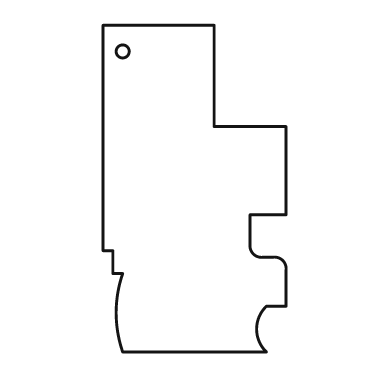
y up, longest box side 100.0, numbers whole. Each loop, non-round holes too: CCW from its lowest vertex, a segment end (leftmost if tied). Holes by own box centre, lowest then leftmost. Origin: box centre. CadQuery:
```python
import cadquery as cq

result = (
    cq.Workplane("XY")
    .moveTo(-22.0, -50.0)
    .lineTo(22.0, -50.0)
    .threePointArc((19.0, -43.0), (22.0, -36.0))
    .lineTo(28.0, -36.0)
    .lineTo(28.0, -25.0)
    .threePointArc((27.0, -22.0), (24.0, -21.0))
    .lineTo(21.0, -21.0)
    .threePointArc((18.0, -20.0), (17.0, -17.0))
    .lineTo(17.0, -8.0)
    .lineTo(28.0, -8.0)
    .lineTo(28.0, 19.0)
    .lineTo(6.0, 19.0)
    .lineTo(6.0, 50.0)
    .lineTo(-28.0, 50.0)
    .lineTo(-28.0, -19.0)
    .lineTo(-25.0, -19.0)
    .lineTo(-25.0, -26.0)
    .lineTo(-22.0, -26.0)
    .threePointArc((-24.0, -38.0), (-22.0, -50.0))
    .close()
    .moveTo(-22.0, 42.0)
    .circle(2.0)
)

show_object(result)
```